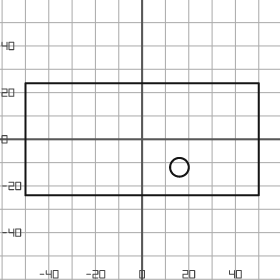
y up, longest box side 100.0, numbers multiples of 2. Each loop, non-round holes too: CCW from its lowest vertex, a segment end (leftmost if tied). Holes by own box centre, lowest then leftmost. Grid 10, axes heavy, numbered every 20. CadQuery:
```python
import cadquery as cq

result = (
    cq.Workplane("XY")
    .moveTo(-50.0, -24.0)
    .lineTo(50.0, -24.0)
    .lineTo(50.0, 24.0)
    .lineTo(-50.0, 24.0)
    .close()
    .moveTo(16.0, -12.0)
    .circle(4.0)
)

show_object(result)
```